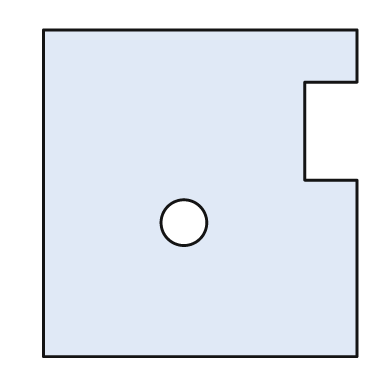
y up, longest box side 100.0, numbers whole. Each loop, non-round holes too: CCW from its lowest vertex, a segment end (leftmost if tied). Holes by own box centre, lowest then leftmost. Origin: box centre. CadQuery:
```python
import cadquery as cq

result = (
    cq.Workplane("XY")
    .moveTo(-48.0, -50.0)
    .lineTo(48.0, -50.0)
    .lineTo(48.0, 4.0)
    .lineTo(32.0, 4.0)
    .lineTo(32.0, 34.0)
    .lineTo(48.0, 34.0)
    .lineTo(48.0, 50.0)
    .lineTo(-48.0, 50.0)
    .close()
    .moveTo(-5.0, -9.0)
    .circle(7.0)
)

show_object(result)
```